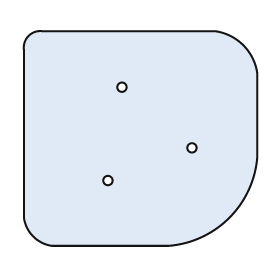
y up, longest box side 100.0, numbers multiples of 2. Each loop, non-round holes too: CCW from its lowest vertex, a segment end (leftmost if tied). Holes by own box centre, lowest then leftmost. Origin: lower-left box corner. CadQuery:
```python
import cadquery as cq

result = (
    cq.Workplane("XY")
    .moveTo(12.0, 0.0)
    .lineTo(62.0, 0.0)
    .threePointArc((88.0, 12.0), (100.0, 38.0))
    .lineTo(100.0, 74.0)
    .threePointArc((94.0, 86.0), (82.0, 92.0))
    .lineTo(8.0, 92.0)
    .threePointArc((2.0, 90.0), (0.0, 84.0))
    .lineTo(0.0, 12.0)
    .threePointArc((4.0, 4.0), (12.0, 0.0))
    .close()
    .moveTo(36.0, 28.0)
    .circle(2.0)
    .moveTo(72.0, 42.0)
    .circle(2.0)
    .moveTo(42.0, 68.0)
    .circle(2.0)
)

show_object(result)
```